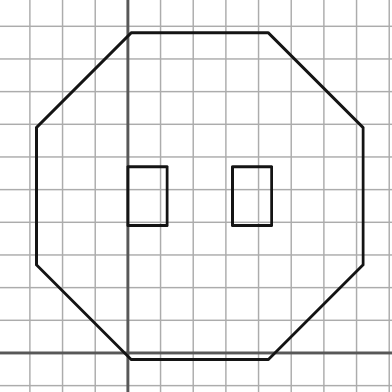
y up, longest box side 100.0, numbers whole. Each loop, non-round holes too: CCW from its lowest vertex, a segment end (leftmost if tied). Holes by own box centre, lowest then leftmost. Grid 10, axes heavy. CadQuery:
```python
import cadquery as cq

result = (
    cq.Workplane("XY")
    .moveTo(1.0, -2.0)
    .lineTo(43.0, -2.0)
    .lineTo(72.0, 27.0)
    .lineTo(72.0, 69.0)
    .lineTo(43.0, 98.0)
    .lineTo(1.0, 98.0)
    .lineTo(-28.0, 69.0)
    .lineTo(-28.0, 27.0)
    .close()
    .moveTo(0.0, 39.0)
    .lineTo(12.0, 39.0)
    .lineTo(12.0, 57.0)
    .lineTo(0.0, 57.0)
    .close()
    .moveTo(32.0, 39.0)
    .lineTo(44.0, 39.0)
    .lineTo(44.0, 57.0)
    .lineTo(32.0, 57.0)
    .close()
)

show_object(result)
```